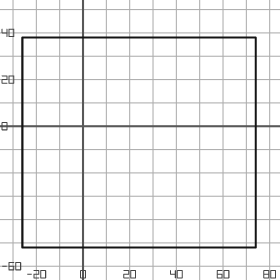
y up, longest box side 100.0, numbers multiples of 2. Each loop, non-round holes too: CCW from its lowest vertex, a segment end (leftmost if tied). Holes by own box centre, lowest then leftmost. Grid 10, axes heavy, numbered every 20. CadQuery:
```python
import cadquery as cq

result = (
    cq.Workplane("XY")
    .moveTo(-26.0, -52.0)
    .lineTo(74.0, -52.0)
    .lineTo(74.0, 38.0)
    .lineTo(-26.0, 38.0)
    .close()
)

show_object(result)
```